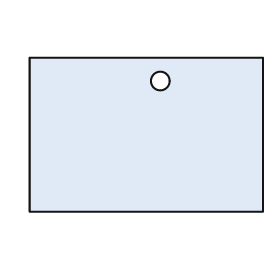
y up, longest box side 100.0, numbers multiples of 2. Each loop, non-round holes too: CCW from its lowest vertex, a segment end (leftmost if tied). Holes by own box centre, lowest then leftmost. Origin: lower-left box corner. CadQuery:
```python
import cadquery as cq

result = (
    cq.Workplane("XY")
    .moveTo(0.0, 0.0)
    .lineTo(100.0, 0.0)
    .lineTo(100.0, 66.0)
    .lineTo(0.0, 66.0)
    .close()
    .moveTo(56.0, 56.0)
    .circle(4.0)
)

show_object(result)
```